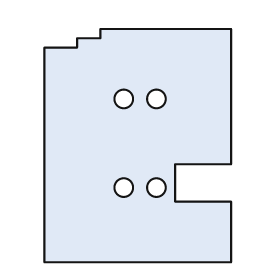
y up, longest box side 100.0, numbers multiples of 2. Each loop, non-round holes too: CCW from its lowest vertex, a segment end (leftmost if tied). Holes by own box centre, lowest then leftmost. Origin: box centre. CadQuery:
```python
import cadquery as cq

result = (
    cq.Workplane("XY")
    .moveTo(-40.0, -50.0)
    .lineTo(40.0, -50.0)
    .lineTo(40.0, -24.0)
    .lineTo(16.0, -24.0)
    .lineTo(16.0, -8.0)
    .lineTo(40.0, -8.0)
    .lineTo(40.0, 50.0)
    .lineTo(-16.0, 50.0)
    .lineTo(-16.0, 46.0)
    .lineTo(-26.0, 46.0)
    .lineTo(-26.0, 42.0)
    .lineTo(-40.0, 42.0)
    .close()
    .moveTo(-6.0, -18.0)
    .circle(4.0)
    .moveTo(8.0, -18.0)
    .circle(4.0)
    .moveTo(-6.0, 20.0)
    .circle(4.0)
    .moveTo(8.0, 20.0)
    .circle(4.0)
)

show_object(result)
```